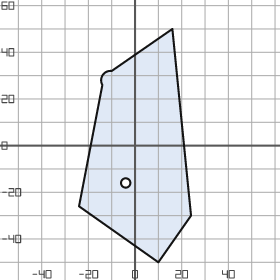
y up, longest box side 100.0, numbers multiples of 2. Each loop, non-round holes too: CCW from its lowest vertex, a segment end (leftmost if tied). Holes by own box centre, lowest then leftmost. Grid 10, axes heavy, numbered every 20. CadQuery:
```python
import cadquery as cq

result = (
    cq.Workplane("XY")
    .moveTo(10.0, -50.0)
    .lineTo(24.0, -30.0)
    .lineTo(16.0, 50.0)
    .lineTo(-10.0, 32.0)
    .threePointArc((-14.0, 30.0), (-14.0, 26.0))
    .lineTo(-24.0, -26.0)
    .close()
    .moveTo(-4.0, -16.0)
    .circle(2.0)
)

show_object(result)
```